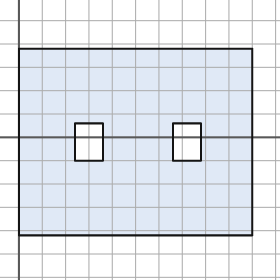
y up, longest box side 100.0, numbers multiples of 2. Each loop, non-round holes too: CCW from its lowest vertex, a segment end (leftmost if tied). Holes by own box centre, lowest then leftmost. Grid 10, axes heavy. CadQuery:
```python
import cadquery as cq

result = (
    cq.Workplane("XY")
    .moveTo(0.0, -42.0)
    .lineTo(100.0, -42.0)
    .lineTo(100.0, 38.0)
    .lineTo(0.0, 38.0)
    .close()
    .moveTo(24.0, -10.0)
    .lineTo(36.0, -10.0)
    .lineTo(36.0, 6.0)
    .lineTo(24.0, 6.0)
    .close()
    .moveTo(66.0, -10.0)
    .lineTo(78.0, -10.0)
    .lineTo(78.0, 6.0)
    .lineTo(66.0, 6.0)
    .close()
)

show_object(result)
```